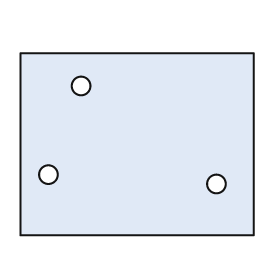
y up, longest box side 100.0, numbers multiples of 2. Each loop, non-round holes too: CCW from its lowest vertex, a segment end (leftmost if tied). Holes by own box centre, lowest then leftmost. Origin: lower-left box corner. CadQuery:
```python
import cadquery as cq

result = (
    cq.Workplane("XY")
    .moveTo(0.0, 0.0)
    .lineTo(100.0, 0.0)
    .lineTo(100.0, 78.0)
    .lineTo(0.0, 78.0)
    .close()
    .moveTo(84.0, 22.0)
    .circle(4.0)
    .moveTo(12.0, 26.0)
    .circle(4.0)
    .moveTo(26.0, 64.0)
    .circle(4.0)
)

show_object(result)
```